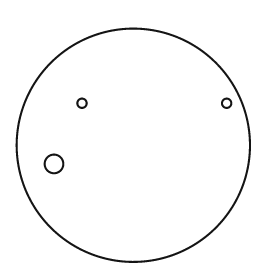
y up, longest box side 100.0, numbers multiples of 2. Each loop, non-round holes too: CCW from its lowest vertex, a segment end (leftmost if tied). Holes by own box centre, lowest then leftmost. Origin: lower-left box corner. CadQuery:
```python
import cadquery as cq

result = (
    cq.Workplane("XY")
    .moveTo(50.0, 50.0)
    .circle(50.0)
    .moveTo(16.0, 42.0)
    .circle(4.0)
    .moveTo(28.0, 68.0)
    .circle(2.0)
    .moveTo(90.0, 68.0)
    .circle(2.0)
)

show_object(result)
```